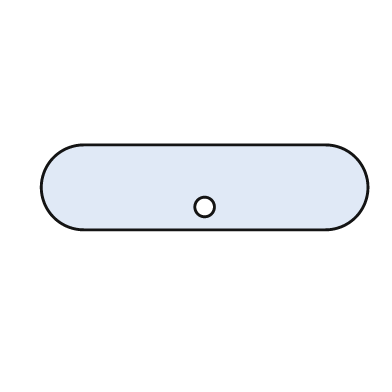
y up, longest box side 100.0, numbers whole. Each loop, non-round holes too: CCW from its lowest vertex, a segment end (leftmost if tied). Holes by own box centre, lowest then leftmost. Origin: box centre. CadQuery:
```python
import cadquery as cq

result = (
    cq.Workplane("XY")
    .moveTo(-37.0, -13.0)
    .lineTo(37.0, -13.0)
    .threePointArc((50.0, 0.0), (37.0, 13.0))
    .lineTo(-37.0, 13.0)
    .threePointArc((-50.0, 0.0), (-37.0, -13.0))
    .close()
    .moveTo(0.0, -6.0)
    .circle(3.0)
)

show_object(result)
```